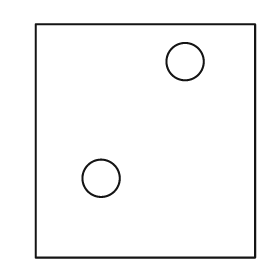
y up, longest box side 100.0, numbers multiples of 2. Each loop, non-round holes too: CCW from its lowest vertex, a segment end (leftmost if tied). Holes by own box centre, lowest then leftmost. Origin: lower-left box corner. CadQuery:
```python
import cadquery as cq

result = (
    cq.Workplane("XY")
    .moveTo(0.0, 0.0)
    .lineTo(94.0, 0.0)
    .lineTo(94.0, 100.0)
    .lineTo(0.0, 100.0)
    .close()
    .moveTo(28.0, 34.0)
    .circle(8.0)
    .moveTo(64.0, 84.0)
    .circle(8.0)
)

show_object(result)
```